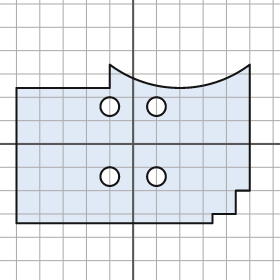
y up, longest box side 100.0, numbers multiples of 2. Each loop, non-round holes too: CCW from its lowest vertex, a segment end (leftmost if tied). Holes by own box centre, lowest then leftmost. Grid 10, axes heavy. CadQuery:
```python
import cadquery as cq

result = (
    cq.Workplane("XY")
    .moveTo(-50.0, -34.0)
    .lineTo(34.0, -34.0)
    .lineTo(34.0, -30.0)
    .lineTo(44.0, -30.0)
    .lineTo(44.0, -20.0)
    .lineTo(50.0, -20.0)
    .lineTo(50.0, 34.0)
    .threePointArc((20.0, 24.0), (-10.0, 34.0))
    .lineTo(-10.0, 24.0)
    .lineTo(-50.0, 24.0)
    .close()
    .moveTo(-10.0, -14.0)
    .circle(4.0)
    .moveTo(10.0, -14.0)
    .circle(4.0)
    .moveTo(-10.0, 16.0)
    .circle(4.0)
    .moveTo(10.0, 16.0)
    .circle(4.0)
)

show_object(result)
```